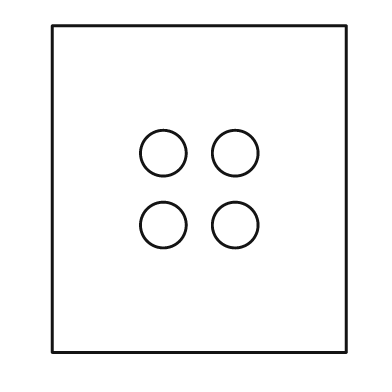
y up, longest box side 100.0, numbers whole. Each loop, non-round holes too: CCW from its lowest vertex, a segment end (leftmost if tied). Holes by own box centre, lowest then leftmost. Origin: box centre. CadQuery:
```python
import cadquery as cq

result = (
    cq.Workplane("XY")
    .moveTo(-45.0, -50.0)
    .lineTo(45.0, -50.0)
    .lineTo(45.0, 50.0)
    .lineTo(-45.0, 50.0)
    .close()
    .moveTo(-11.0, -11.0)
    .circle(7.0)
    .moveTo(11.0, -11.0)
    .circle(7.0)
    .moveTo(-11.0, 11.0)
    .circle(7.0)
    .moveTo(11.0, 11.0)
    .circle(7.0)
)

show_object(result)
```